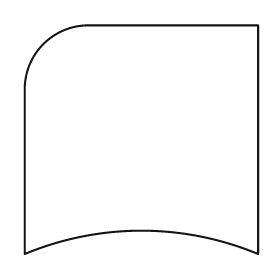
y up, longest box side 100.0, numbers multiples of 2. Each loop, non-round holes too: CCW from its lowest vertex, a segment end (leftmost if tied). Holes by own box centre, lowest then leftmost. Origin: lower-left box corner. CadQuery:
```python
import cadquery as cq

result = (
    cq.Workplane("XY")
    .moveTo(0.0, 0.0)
    .threePointArc((50.0, 10.0), (100.0, 0.0))
    .lineTo(100.0, 98.0)
    .lineTo(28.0, 98.0)
    .threePointArc((8.0, 90.0), (0.0, 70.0))
    .close()
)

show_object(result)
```